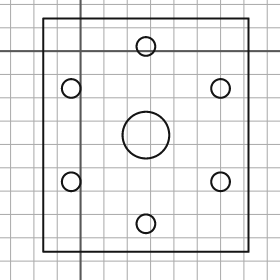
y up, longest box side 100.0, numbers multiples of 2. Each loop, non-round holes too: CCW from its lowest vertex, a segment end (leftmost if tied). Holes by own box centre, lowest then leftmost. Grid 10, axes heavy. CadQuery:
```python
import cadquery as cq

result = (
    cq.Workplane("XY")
    .moveTo(-16.0, -86.0)
    .lineTo(72.0, -86.0)
    .lineTo(72.0, 14.0)
    .lineTo(-16.0, 14.0)
    .close()
    .moveTo(28.0, -74.0)
    .circle(4.0)
    .moveTo(-4.0, -56.0)
    .circle(4.0)
    .moveTo(60.0, -56.0)
    .circle(4.0)
    .moveTo(28.0, -36.0)
    .circle(10.0)
    .moveTo(-4.0, -16.0)
    .circle(4.0)
    .moveTo(60.0, -16.0)
    .circle(4.0)
    .moveTo(28.0, 2.0)
    .circle(4.0)
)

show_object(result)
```